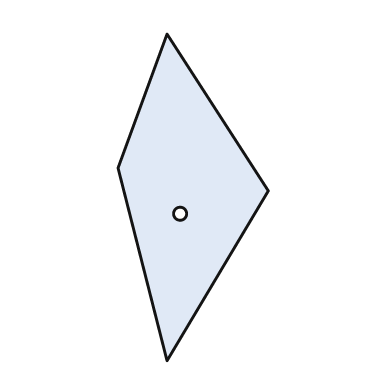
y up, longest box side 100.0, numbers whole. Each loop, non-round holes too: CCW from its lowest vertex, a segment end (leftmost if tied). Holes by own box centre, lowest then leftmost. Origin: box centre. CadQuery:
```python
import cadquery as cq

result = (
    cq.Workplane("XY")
    .moveTo(-8.0, -50.0)
    .lineTo(23.0, 2.0)
    .lineTo(-8.0, 50.0)
    .lineTo(-23.0, 9.0)
    .close()
    .moveTo(-4.0, -5.0)
    .circle(2.0)
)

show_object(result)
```